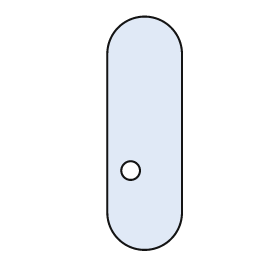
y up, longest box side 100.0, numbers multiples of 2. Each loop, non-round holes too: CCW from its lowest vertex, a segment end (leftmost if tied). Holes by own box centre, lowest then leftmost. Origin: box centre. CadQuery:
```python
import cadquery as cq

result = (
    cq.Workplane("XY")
    .moveTo(-16.0, -34.0)
    .threePointArc((0.0, -50.0), (16.0, -34.0))
    .lineTo(16.0, 34.0)
    .threePointArc((0.0, 50.0), (-16.0, 34.0))
    .close()
    .moveTo(-6.0, -16.0)
    .circle(4.0)
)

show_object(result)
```